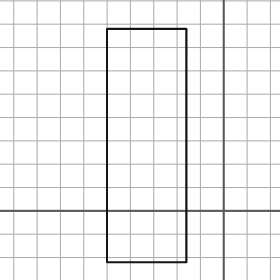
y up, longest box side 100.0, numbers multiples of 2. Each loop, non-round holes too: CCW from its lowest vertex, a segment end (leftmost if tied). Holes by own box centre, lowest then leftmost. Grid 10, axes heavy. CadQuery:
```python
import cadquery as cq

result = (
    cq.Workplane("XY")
    .moveTo(-50.0, -22.0)
    .lineTo(-16.0, -22.0)
    .lineTo(-16.0, 78.0)
    .lineTo(-50.0, 78.0)
    .close()
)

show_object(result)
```